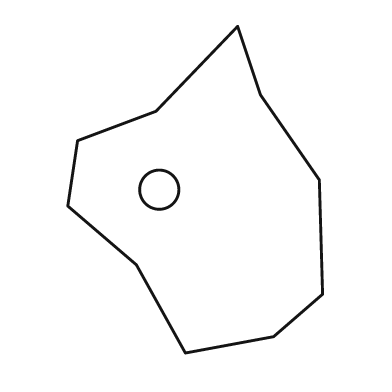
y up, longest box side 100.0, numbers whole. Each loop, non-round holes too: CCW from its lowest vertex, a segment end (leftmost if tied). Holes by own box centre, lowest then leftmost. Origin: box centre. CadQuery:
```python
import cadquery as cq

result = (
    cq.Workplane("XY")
    .moveTo(-3.0, -50.0)
    .lineTo(24.0, -45.0)
    .lineTo(39.0, -32.0)
    .lineTo(38.0, 3.0)
    .lineTo(20.0, 29.0)
    .lineTo(13.0, 50.0)
    .lineTo(-12.0, 24.0)
    .lineTo(-36.0, 15.0)
    .lineTo(-39.0, -5.0)
    .lineTo(-18.0, -23.0)
    .close()
    .moveTo(-11.0, 0.0)
    .circle(6.0)
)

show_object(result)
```